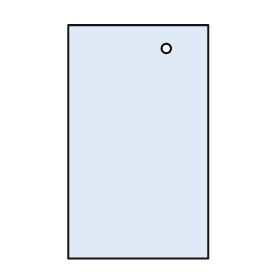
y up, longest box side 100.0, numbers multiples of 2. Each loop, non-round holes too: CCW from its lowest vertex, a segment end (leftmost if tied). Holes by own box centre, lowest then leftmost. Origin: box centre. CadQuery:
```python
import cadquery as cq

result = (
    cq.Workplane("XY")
    .moveTo(-30.0, -50.0)
    .lineTo(30.0, -50.0)
    .lineTo(30.0, 50.0)
    .lineTo(-30.0, 50.0)
    .close()
    .moveTo(12.0, 40.0)
    .circle(2.0)
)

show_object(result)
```